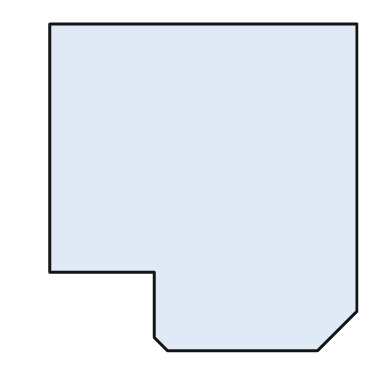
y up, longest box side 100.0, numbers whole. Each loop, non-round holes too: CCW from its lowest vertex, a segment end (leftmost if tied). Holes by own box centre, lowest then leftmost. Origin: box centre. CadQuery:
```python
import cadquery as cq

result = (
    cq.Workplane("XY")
    .moveTo(-11.0, -50.0)
    .lineTo(35.0, -50.0)
    .lineTo(47.0, -38.0)
    .lineTo(47.0, 50.0)
    .lineTo(-47.0, 50.0)
    .lineTo(-47.0, -26.0)
    .lineTo(-15.0, -26.0)
    .lineTo(-15.0, -46.0)
    .close()
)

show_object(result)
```